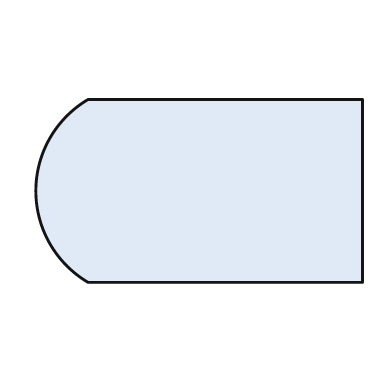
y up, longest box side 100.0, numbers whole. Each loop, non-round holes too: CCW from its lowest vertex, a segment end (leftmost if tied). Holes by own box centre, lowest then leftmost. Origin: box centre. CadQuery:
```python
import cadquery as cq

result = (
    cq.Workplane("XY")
    .moveTo(-34.0, -28.0)
    .lineTo(50.0, -28.0)
    .lineTo(50.0, 28.0)
    .lineTo(-34.0, 28.0)
    .threePointArc((-50.0, 0.0), (-34.0, -28.0))
    .close()
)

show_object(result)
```